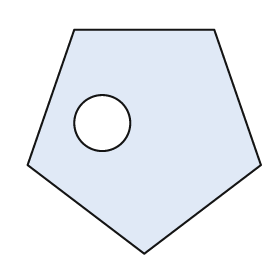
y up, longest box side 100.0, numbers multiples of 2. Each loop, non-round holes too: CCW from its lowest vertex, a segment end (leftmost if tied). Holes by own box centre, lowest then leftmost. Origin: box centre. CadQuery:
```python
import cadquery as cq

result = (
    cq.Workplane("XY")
    .moveTo(0.0, -48.0)
    .lineTo(50.0, -10.0)
    .lineTo(30.0, 48.0)
    .lineTo(-30.0, 48.0)
    .lineTo(-50.0, -10.0)
    .close()
    .moveTo(-18.0, 8.0)
    .circle(12.0)
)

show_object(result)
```